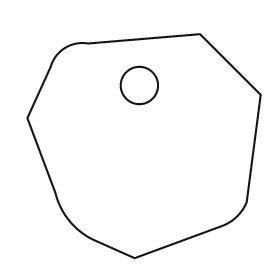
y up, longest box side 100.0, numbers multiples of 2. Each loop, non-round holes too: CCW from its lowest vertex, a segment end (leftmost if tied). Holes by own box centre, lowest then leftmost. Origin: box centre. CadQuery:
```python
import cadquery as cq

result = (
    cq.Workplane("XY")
    .moveTo(-4.0, -48.0)
    .lineTo(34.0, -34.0)
    .threePointArc((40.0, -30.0), (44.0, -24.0))
    .lineTo(50.0, 22.0)
    .lineTo(24.0, 48.0)
    .lineTo(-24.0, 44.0)
    .threePointArc((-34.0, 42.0), (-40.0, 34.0))
    .lineTo(-50.0, 12.0)
    .lineTo(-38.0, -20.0)
    .threePointArc((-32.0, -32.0), (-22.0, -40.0))
    .close()
    .moveTo(-2.0, 26.0)
    .circle(8.0)
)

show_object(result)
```